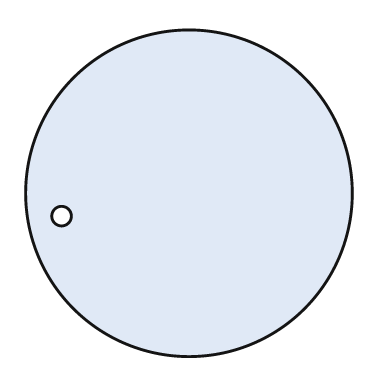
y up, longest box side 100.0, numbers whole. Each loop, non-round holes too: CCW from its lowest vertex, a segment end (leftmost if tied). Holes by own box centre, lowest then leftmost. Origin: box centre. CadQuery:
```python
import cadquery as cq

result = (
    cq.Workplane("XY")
    .moveTo(0.0, 0.0)
    .circle(50.0)
    .moveTo(-39.0, -7.0)
    .circle(3.0)
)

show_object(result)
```